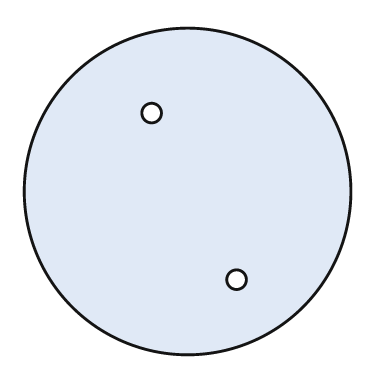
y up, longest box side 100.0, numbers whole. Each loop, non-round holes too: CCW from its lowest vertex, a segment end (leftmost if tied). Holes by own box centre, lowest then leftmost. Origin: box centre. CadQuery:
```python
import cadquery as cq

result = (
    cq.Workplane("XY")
    .moveTo(0.0, 0.0)
    .circle(50.0)
    .moveTo(15.0, -27.0)
    .circle(3.0)
    .moveTo(-11.0, 24.0)
    .circle(3.0)
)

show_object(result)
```